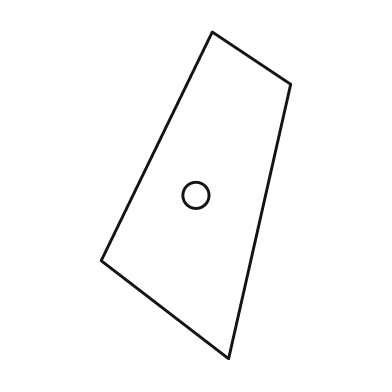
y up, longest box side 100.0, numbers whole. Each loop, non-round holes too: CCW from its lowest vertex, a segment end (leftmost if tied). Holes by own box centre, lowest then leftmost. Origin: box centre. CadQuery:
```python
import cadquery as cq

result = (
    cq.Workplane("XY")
    .moveTo(10.0, -50.0)
    .lineTo(29.0, 34.0)
    .lineTo(5.0, 50.0)
    .lineTo(-29.0, -20.0)
    .close()
    .moveTo(0.0, 0.0)
    .circle(4.0)
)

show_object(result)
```